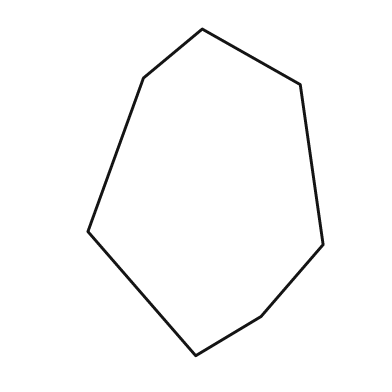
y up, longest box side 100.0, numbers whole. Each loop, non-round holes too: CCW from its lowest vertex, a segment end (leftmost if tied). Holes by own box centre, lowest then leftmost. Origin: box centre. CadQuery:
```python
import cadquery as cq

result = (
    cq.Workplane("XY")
    .moveTo(-3.0, -50.0)
    .lineTo(17.0, -38.0)
    .lineTo(36.0, -16.0)
    .lineTo(29.0, 33.0)
    .lineTo(-1.0, 50.0)
    .lineTo(-19.0, 35.0)
    .lineTo(-36.0, -12.0)
    .close()
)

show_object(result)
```